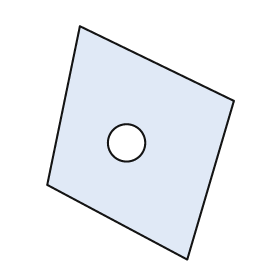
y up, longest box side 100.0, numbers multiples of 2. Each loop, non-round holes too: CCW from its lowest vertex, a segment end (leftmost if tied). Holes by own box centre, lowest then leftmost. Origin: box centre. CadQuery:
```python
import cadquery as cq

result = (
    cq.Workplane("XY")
    .moveTo(20.0, -50.0)
    .lineTo(40.0, 18.0)
    .lineTo(-26.0, 50.0)
    .lineTo(-40.0, -18.0)
    .close()
    .moveTo(-6.0, 0.0)
    .circle(8.0)
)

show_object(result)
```